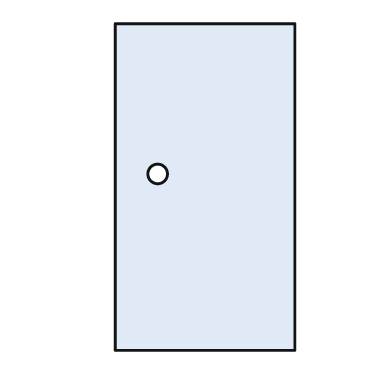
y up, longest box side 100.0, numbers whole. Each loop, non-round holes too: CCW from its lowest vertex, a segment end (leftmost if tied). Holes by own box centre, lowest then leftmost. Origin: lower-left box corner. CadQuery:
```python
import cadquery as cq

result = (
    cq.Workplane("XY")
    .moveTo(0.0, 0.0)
    .lineTo(55.0, 0.0)
    .lineTo(55.0, 100.0)
    .lineTo(0.0, 100.0)
    .close()
    .moveTo(13.0, 54.0)
    .circle(3.0)
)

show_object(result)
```